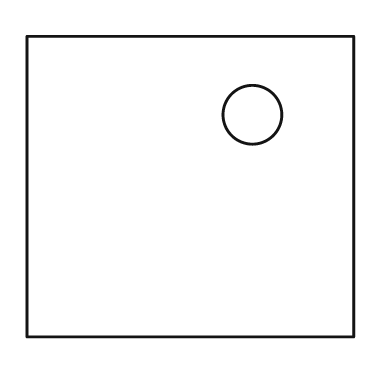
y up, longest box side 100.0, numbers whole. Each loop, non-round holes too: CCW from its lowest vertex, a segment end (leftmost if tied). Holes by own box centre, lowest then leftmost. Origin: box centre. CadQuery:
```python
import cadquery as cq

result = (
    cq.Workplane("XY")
    .moveTo(-50.0, -46.0)
    .lineTo(50.0, -46.0)
    .lineTo(50.0, 46.0)
    .lineTo(-50.0, 46.0)
    .close()
    .moveTo(19.0, 22.0)
    .circle(9.0)
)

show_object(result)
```